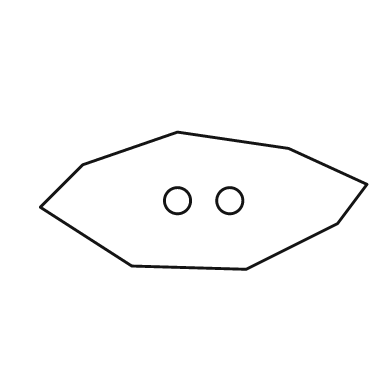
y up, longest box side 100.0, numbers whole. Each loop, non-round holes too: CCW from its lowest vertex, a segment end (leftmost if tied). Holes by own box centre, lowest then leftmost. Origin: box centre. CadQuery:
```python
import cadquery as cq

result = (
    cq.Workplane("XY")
    .moveTo(13.0, -21.0)
    .lineTo(41.0, -7.0)
    .lineTo(50.0, 5.0)
    .lineTo(26.0, 16.0)
    .lineTo(-8.0, 21.0)
    .lineTo(-37.0, 11.0)
    .lineTo(-50.0, -2.0)
    .lineTo(-22.0, -20.0)
    .close()
    .moveTo(-8.0, 0.0)
    .circle(4.0)
    .moveTo(8.0, 0.0)
    .circle(4.0)
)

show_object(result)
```